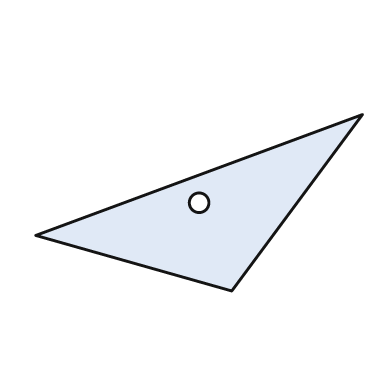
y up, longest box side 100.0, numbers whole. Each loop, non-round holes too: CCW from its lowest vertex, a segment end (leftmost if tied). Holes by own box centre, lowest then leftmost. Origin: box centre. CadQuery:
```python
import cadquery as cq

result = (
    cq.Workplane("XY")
    .moveTo(10.0, -27.0)
    .lineTo(50.0, 27.0)
    .lineTo(-50.0, -10.0)
    .close()
    .moveTo(0.0, 0.0)
    .circle(3.0)
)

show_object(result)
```